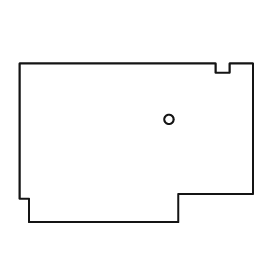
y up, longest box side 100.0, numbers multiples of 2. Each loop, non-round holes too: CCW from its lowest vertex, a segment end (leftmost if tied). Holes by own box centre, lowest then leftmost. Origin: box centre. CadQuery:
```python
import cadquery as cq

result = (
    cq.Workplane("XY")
    .moveTo(-46.0, -34.0)
    .lineTo(18.0, -34.0)
    .lineTo(18.0, -22.0)
    .lineTo(50.0, -22.0)
    .lineTo(50.0, 34.0)
    .lineTo(40.0, 34.0)
    .lineTo(40.0, 30.0)
    .lineTo(34.0, 30.0)
    .lineTo(34.0, 34.0)
    .lineTo(-50.0, 34.0)
    .lineTo(-50.0, -24.0)
    .lineTo(-46.0, -24.0)
    .close()
    .moveTo(14.0, 10.0)
    .circle(2.0)
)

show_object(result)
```